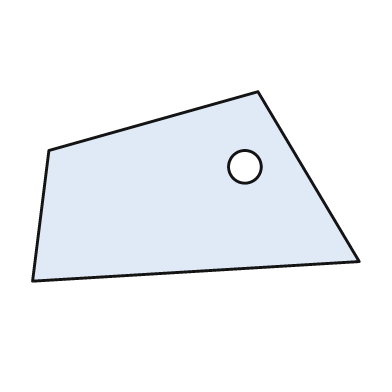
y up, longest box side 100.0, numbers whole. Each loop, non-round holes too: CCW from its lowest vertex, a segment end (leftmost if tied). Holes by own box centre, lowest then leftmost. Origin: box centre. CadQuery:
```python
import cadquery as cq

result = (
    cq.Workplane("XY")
    .moveTo(-50.0, -29.0)
    .lineTo(50.0, -23.0)
    .lineTo(19.0, 29.0)
    .lineTo(-45.0, 11.0)
    .close()
    .moveTo(15.0, 6.0)
    .circle(5.0)
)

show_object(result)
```